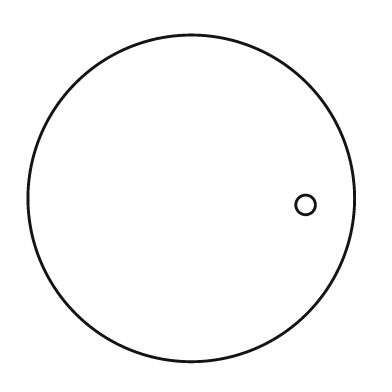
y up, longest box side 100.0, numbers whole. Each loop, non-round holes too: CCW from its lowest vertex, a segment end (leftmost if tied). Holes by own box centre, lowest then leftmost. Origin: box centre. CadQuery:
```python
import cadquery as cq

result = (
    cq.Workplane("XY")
    .moveTo(0.0, 0.0)
    .circle(50.0)
    .moveTo(35.0, -2.0)
    .circle(3.0)
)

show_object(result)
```